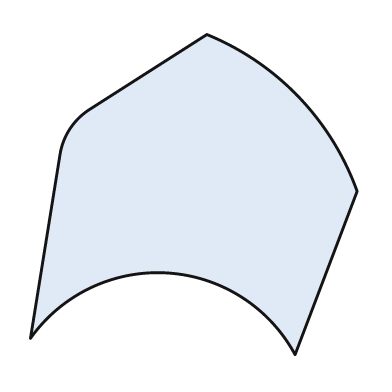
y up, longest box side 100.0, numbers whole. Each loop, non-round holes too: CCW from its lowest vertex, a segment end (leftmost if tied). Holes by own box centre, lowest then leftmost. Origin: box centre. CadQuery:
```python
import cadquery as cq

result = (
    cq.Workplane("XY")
    .moveTo(31.0, -49.0)
    .lineTo(50.0, 1.0)
    .threePointArc((32.0, 30.0), (4.0, 49.0))
    .lineTo(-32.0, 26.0)
    .threePointArc((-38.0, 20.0), (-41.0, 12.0))
    .lineTo(-50.0, -44.0)
    .threePointArc((-8.0, -24.0), (31.0, -49.0))
    .close()
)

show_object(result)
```